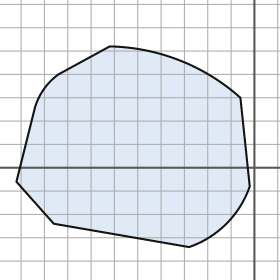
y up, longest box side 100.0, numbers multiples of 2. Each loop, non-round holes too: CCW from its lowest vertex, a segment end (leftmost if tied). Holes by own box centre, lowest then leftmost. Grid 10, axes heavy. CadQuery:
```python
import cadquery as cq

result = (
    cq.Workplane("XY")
    .moveTo(-28.0, -34.0)
    .threePointArc((-12.0, -24.0), (-2.0, -8.0))
    .lineTo(-6.0, 30.0)
    .threePointArc((-32.0, 46.0), (-62.0, 52.0))
    .lineTo(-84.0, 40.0)
    .threePointArc((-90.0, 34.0), (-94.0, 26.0))
    .lineTo(-102.0, -6.0)
    .lineTo(-86.0, -24.0)
    .close()
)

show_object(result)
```